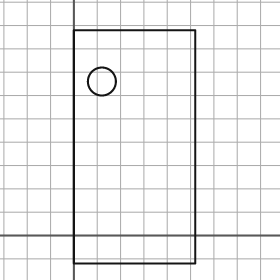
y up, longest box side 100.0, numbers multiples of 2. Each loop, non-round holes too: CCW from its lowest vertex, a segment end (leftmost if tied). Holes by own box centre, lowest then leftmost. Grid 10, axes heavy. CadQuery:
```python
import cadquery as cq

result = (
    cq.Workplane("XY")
    .moveTo(0.0, -12.0)
    .lineTo(52.0, -12.0)
    .lineTo(52.0, 88.0)
    .lineTo(0.0, 88.0)
    .close()
    .moveTo(12.0, 66.0)
    .circle(6.0)
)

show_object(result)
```